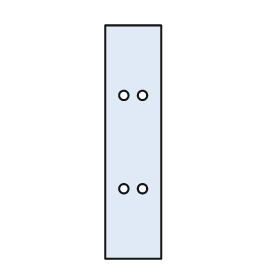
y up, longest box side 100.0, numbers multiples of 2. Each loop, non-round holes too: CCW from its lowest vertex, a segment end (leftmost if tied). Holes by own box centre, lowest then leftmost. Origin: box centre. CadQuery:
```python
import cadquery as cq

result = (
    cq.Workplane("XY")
    .moveTo(-12.0, -50.0)
    .lineTo(12.0, -50.0)
    .lineTo(12.0, 50.0)
    .lineTo(-12.0, 50.0)
    .close()
    .moveTo(-4.0, -20.0)
    .circle(2.0)
    .moveTo(4.0, -20.0)
    .circle(2.0)
    .moveTo(-4.0, 20.0)
    .circle(2.0)
    .moveTo(4.0, 20.0)
    .circle(2.0)
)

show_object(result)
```